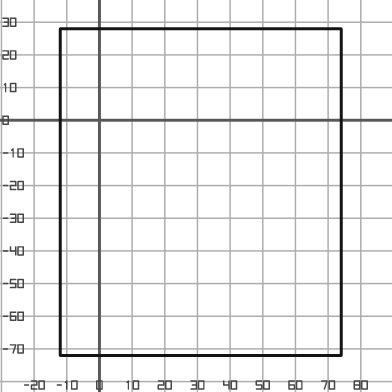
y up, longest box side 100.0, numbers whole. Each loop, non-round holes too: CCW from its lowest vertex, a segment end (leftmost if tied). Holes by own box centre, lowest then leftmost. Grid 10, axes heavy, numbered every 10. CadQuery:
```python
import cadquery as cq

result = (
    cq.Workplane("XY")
    .moveTo(-12.0, -72.0)
    .lineTo(74.0, -72.0)
    .lineTo(74.0, 28.0)
    .lineTo(-12.0, 28.0)
    .close()
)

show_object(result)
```